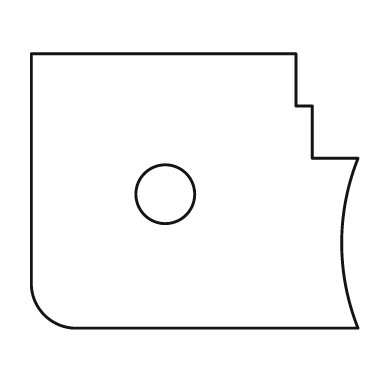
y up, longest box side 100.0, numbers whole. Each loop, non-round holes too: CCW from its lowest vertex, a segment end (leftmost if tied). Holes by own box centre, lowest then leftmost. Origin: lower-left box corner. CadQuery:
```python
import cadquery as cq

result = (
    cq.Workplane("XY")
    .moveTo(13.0, 0.0)
    .lineTo(100.0, 0.0)
    .threePointArc((95.0, 26.0), (100.0, 52.0))
    .lineTo(86.0, 52.0)
    .lineTo(86.0, 68.0)
    .lineTo(81.0, 68.0)
    .lineTo(81.0, 84.0)
    .lineTo(0.0, 84.0)
    .lineTo(0.0, 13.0)
    .threePointArc((4.0, 4.0), (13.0, 0.0))
    .close()
    .moveTo(41.0, 41.0)
    .circle(9.0)
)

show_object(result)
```